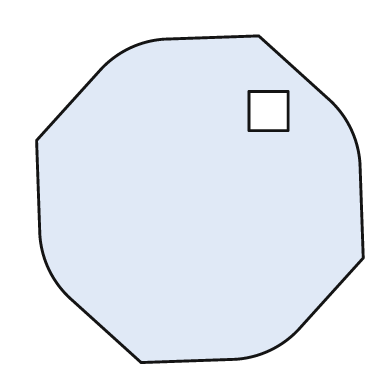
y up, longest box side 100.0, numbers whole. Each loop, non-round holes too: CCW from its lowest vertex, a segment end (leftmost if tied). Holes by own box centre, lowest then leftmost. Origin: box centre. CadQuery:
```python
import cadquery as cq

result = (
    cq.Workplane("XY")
    .moveTo(-18.0, -50.0)
    .lineTo(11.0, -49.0)
    .threePointArc((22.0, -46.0), (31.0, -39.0))
    .lineTo(50.0, -18.0)
    .lineTo(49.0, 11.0)
    .threePointArc((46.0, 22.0), (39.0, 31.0))
    .lineTo(18.0, 50.0)
    .lineTo(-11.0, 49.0)
    .threePointArc((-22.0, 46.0), (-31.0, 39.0))
    .lineTo(-50.0, 18.0)
    .lineTo(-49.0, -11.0)
    .threePointArc((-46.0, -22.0), (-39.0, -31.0))
    .close()
    .moveTo(15.0, 21.0)
    .lineTo(27.0, 21.0)
    .lineTo(27.0, 33.0)
    .lineTo(15.0, 33.0)
    .close()
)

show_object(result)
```